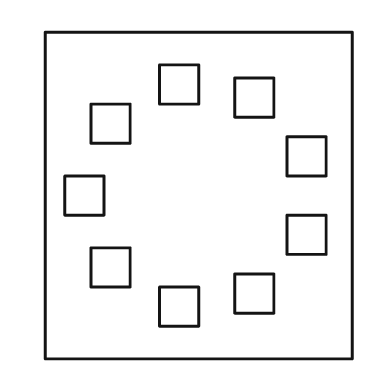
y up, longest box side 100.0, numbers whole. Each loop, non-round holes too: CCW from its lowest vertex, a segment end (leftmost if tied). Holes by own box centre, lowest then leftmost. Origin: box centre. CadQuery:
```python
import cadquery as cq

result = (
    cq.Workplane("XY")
    .moveTo(-47.0, -50.0)
    .lineTo(47.0, -50.0)
    .lineTo(47.0, 50.0)
    .lineTo(-47.0, 50.0)
    .close()
    .moveTo(-12.0, -40.0)
    .lineTo(0.0, -40.0)
    .lineTo(0.0, -28.0)
    .lineTo(-12.0, -28.0)
    .close()
    .moveTo(11.0, -36.0)
    .lineTo(23.0, -36.0)
    .lineTo(23.0, -24.0)
    .lineTo(11.0, -24.0)
    .close()
    .moveTo(-33.0, -28.0)
    .lineTo(-21.0, -28.0)
    .lineTo(-21.0, -16.0)
    .lineTo(-33.0, -16.0)
    .close()
    .moveTo(27.0, -18.0)
    .lineTo(39.0, -18.0)
    .lineTo(39.0, -6.0)
    .lineTo(27.0, -6.0)
    .close()
    .moveTo(-41.0, -6.0)
    .lineTo(-29.0, -6.0)
    .lineTo(-29.0, 6.0)
    .lineTo(-41.0, 6.0)
    .close()
    .moveTo(27.0, 6.0)
    .lineTo(39.0, 6.0)
    .lineTo(39.0, 18.0)
    .lineTo(27.0, 18.0)
    .close()
    .moveTo(-33.0, 16.0)
    .lineTo(-21.0, 16.0)
    .lineTo(-21.0, 28.0)
    .lineTo(-33.0, 28.0)
    .close()
    .moveTo(11.0, 24.0)
    .lineTo(23.0, 24.0)
    .lineTo(23.0, 36.0)
    .lineTo(11.0, 36.0)
    .close()
    .moveTo(-12.0, 28.0)
    .lineTo(0.0, 28.0)
    .lineTo(0.0, 40.0)
    .lineTo(-12.0, 40.0)
    .close()
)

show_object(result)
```